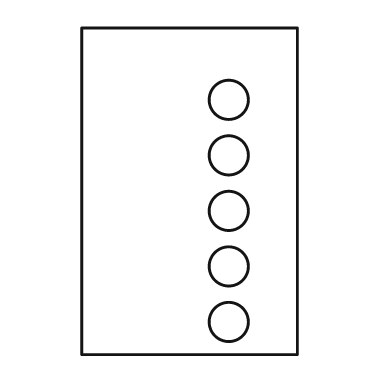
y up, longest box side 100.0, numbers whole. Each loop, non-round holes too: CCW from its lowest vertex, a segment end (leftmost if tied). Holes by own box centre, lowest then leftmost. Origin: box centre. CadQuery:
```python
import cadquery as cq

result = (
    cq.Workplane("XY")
    .moveTo(-33.0, -50.0)
    .lineTo(33.0, -50.0)
    .lineTo(33.0, 50.0)
    .lineTo(-33.0, 50.0)
    .close()
    .moveTo(12.0, -40.0)
    .circle(6.0)
    .moveTo(12.0, -23.0)
    .circle(6.0)
    .moveTo(12.0, -6.0)
    .circle(6.0)
    .moveTo(12.0, 11.0)
    .circle(6.0)
    .moveTo(12.0, 28.0)
    .circle(6.0)
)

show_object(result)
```